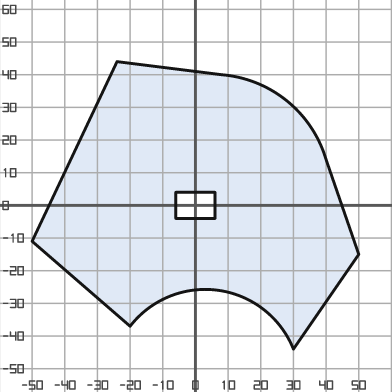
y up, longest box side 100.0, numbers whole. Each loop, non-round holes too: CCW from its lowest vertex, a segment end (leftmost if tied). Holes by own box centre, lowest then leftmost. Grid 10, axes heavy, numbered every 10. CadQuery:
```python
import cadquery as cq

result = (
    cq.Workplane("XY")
    .moveTo(30.0, -44.0)
    .lineTo(50.0, -15.0)
    .lineTo(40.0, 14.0)
    .threePointArc((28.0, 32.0), (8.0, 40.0))
    .lineTo(-24.0, 44.0)
    .lineTo(-50.0, -11.0)
    .lineTo(-20.0, -37.0)
    .threePointArc((7.0, -26.0), (30.0, -44.0))
    .close()
    .moveTo(-6.0, -4.0)
    .lineTo(6.0, -4.0)
    .lineTo(6.0, 4.0)
    .lineTo(-6.0, 4.0)
    .close()
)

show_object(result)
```